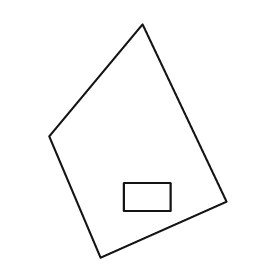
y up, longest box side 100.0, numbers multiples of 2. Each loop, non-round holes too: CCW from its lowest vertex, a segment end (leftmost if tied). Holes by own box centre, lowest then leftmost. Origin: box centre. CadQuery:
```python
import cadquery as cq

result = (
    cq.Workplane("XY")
    .moveTo(-16.0, -50.0)
    .lineTo(38.0, -26.0)
    .lineTo(2.0, 50.0)
    .lineTo(-38.0, 2.0)
    .close()
    .moveTo(-6.0, -30.0)
    .lineTo(14.0, -30.0)
    .lineTo(14.0, -18.0)
    .lineTo(-6.0, -18.0)
    .close()
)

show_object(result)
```